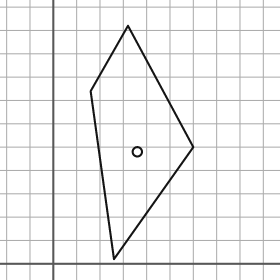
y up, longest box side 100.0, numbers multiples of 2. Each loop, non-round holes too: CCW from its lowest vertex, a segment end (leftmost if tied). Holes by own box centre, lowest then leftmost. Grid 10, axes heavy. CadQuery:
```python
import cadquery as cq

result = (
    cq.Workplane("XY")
    .moveTo(26.0, 2.0)
    .lineTo(60.0, 50.0)
    .lineTo(32.0, 102.0)
    .lineTo(16.0, 74.0)
    .close()
    .moveTo(36.0, 48.0)
    .circle(2.0)
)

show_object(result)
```